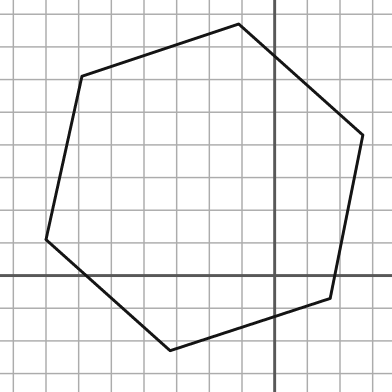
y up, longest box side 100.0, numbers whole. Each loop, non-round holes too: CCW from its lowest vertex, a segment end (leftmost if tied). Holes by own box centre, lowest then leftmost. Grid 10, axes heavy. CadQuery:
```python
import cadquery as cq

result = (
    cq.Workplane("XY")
    .moveTo(-32.0, -23.0)
    .lineTo(17.0, -7.0)
    .lineTo(27.0, 43.0)
    .lineTo(-11.0, 77.0)
    .lineTo(-59.0, 61.0)
    .lineTo(-70.0, 11.0)
    .close()
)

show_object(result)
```